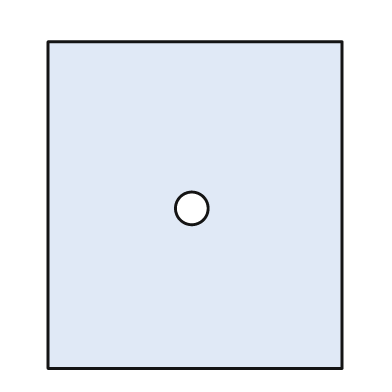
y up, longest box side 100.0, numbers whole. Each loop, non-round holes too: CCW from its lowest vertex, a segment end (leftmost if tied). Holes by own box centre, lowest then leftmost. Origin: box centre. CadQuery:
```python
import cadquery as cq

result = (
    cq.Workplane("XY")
    .moveTo(-45.0, -50.0)
    .lineTo(45.0, -50.0)
    .lineTo(45.0, 50.0)
    .lineTo(-45.0, 50.0)
    .close()
    .moveTo(-1.0, -1.0)
    .circle(5.0)
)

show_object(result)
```